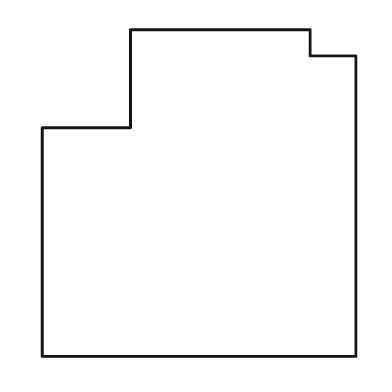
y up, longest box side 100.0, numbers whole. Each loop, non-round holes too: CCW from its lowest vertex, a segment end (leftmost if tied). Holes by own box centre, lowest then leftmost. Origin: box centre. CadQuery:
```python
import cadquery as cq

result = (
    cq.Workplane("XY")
    .moveTo(-48.0, -50.0)
    .lineTo(48.0, -50.0)
    .lineTo(48.0, 42.0)
    .lineTo(34.0, 42.0)
    .lineTo(34.0, 50.0)
    .lineTo(-21.0, 50.0)
    .lineTo(-21.0, 20.0)
    .lineTo(-48.0, 20.0)
    .close()
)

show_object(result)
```